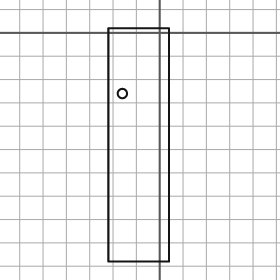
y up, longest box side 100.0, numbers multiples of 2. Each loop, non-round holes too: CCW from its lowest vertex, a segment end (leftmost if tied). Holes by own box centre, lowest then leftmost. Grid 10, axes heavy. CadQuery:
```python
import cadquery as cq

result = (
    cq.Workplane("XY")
    .moveTo(-22.0, -98.0)
    .lineTo(4.0, -98.0)
    .lineTo(4.0, 2.0)
    .lineTo(-22.0, 2.0)
    .close()
    .moveTo(-16.0, -26.0)
    .circle(2.0)
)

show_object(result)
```